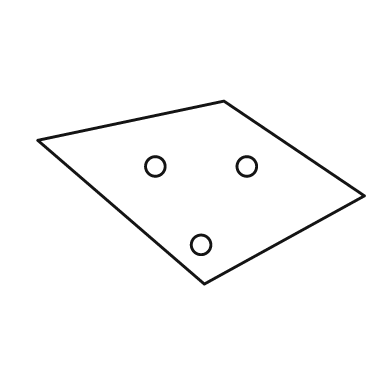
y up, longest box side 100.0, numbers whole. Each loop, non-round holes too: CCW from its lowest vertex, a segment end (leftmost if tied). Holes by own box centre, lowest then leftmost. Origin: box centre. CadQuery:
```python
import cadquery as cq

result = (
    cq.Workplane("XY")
    .moveTo(1.0, -28.0)
    .lineTo(50.0, -1.0)
    .lineTo(7.0, 28.0)
    .lineTo(-50.0, 16.0)
    .close()
    .moveTo(0.0, -16.0)
    .circle(3.0)
    .moveTo(-14.0, 8.0)
    .circle(3.0)
    .moveTo(14.0, 8.0)
    .circle(3.0)
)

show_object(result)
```